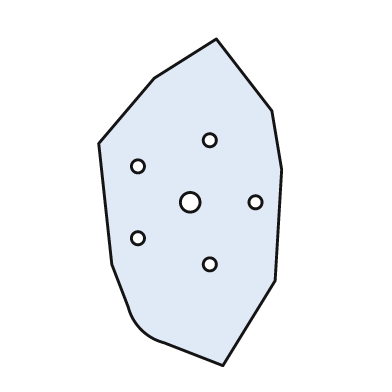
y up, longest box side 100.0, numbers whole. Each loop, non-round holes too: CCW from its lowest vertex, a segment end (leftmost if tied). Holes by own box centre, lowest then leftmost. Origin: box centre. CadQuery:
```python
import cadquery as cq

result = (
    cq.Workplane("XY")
    .moveTo(10.0, -50.0)
    .lineTo(26.0, -24.0)
    .lineTo(28.0, 10.0)
    .lineTo(25.0, 28.0)
    .lineTo(8.0, 50.0)
    .lineTo(-11.0, 38.0)
    .lineTo(-28.0, 18.0)
    .lineTo(-24.0, -19.0)
    .lineTo(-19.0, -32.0)
    .threePointArc((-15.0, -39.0), (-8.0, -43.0))
    .close()
    .moveTo(6.0, -19.0)
    .circle(2.0)
    .moveTo(-16.0, -11.0)
    .circle(2.0)
    .moveTo(0.0, 0.0)
    .circle(3.0)
    .moveTo(20.0, 0.0)
    .circle(2.0)
    .moveTo(-16.0, 11.0)
    .circle(2.0)
    .moveTo(6.0, 19.0)
    .circle(2.0)
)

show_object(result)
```